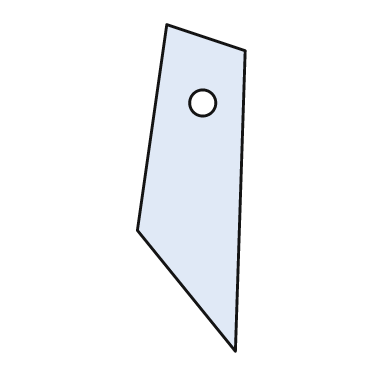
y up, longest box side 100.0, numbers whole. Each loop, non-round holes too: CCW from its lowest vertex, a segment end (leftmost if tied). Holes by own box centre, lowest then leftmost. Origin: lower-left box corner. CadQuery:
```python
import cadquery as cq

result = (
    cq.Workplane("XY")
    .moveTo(30.0, 0.0)
    .lineTo(33.0, 92.0)
    .lineTo(9.0, 100.0)
    .lineTo(0.0, 37.0)
    .close()
    .moveTo(20.0, 76.0)
    .circle(4.0)
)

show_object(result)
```